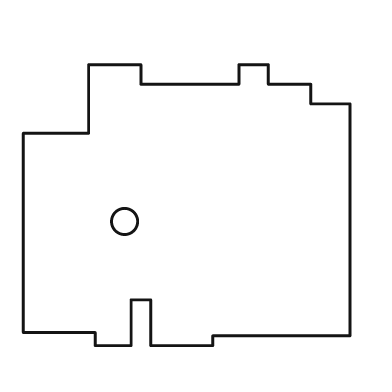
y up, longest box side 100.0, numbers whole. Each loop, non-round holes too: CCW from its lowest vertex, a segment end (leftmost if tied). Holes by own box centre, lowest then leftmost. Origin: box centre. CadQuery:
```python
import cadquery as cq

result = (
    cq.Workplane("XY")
    .moveTo(-28.0, -43.0)
    .lineTo(-17.0, -43.0)
    .lineTo(-17.0, -29.0)
    .lineTo(-11.0, -29.0)
    .lineTo(-11.0, -43.0)
    .lineTo(8.0, -43.0)
    .lineTo(8.0, -40.0)
    .lineTo(50.0, -40.0)
    .lineTo(50.0, 31.0)
    .lineTo(38.0, 31.0)
    .lineTo(38.0, 37.0)
    .lineTo(25.0, 37.0)
    .lineTo(25.0, 43.0)
    .lineTo(16.0, 43.0)
    .lineTo(16.0, 37.0)
    .lineTo(-14.0, 37.0)
    .lineTo(-14.0, 43.0)
    .lineTo(-30.0, 43.0)
    .lineTo(-30.0, 22.0)
    .lineTo(-50.0, 22.0)
    .lineTo(-50.0, -39.0)
    .lineTo(-28.0, -39.0)
    .close()
    .moveTo(-19.0, -5.0)
    .circle(4.0)
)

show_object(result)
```